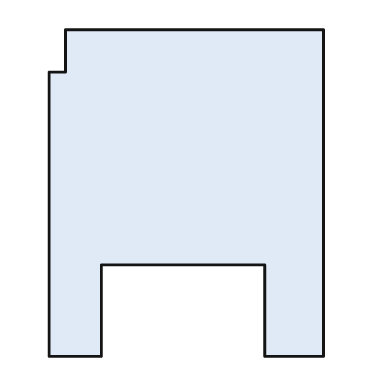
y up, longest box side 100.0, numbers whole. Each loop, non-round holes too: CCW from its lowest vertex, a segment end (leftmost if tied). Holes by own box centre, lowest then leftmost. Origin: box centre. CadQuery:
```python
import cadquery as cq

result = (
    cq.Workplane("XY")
    .moveTo(-42.0, -50.0)
    .lineTo(-26.0, -50.0)
    .lineTo(-26.0, -22.0)
    .lineTo(24.0, -22.0)
    .lineTo(24.0, -50.0)
    .lineTo(42.0, -50.0)
    .lineTo(42.0, 50.0)
    .lineTo(-37.0, 50.0)
    .lineTo(-37.0, 37.0)
    .lineTo(-42.0, 37.0)
    .close()
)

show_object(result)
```